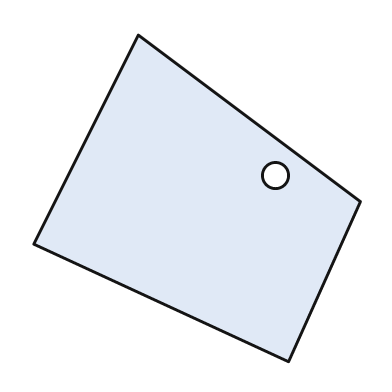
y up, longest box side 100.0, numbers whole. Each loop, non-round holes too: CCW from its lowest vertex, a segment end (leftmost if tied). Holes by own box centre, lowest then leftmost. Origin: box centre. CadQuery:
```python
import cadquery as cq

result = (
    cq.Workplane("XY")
    .moveTo(28.0, -50.0)
    .lineTo(50.0, -1.0)
    .lineTo(-18.0, 50.0)
    .lineTo(-50.0, -14.0)
    .close()
    .moveTo(24.0, 7.0)
    .circle(4.0)
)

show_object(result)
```